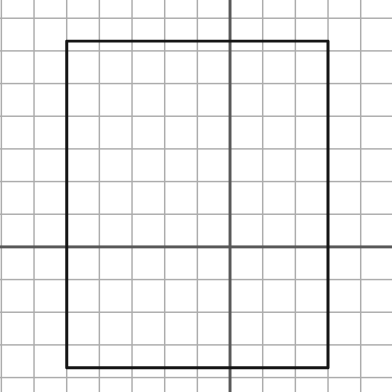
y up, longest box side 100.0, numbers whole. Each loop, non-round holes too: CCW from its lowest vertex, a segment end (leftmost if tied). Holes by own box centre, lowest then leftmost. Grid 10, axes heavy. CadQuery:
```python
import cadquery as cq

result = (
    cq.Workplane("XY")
    .moveTo(-50.0, -37.0)
    .lineTo(30.0, -37.0)
    .lineTo(30.0, 63.0)
    .lineTo(-50.0, 63.0)
    .close()
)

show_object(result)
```